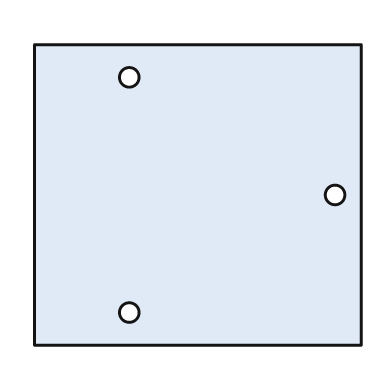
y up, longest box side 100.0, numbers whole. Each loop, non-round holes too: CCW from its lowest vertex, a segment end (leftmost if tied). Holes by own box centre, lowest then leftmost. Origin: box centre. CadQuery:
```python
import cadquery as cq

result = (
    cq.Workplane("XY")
    .moveTo(-50.0, -46.0)
    .lineTo(50.0, -46.0)
    .lineTo(50.0, 46.0)
    .lineTo(-50.0, 46.0)
    .close()
    .moveTo(-21.0, -36.0)
    .circle(3.0)
    .moveTo(42.0, 0.0)
    .circle(3.0)
    .moveTo(-21.0, 36.0)
    .circle(3.0)
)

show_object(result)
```